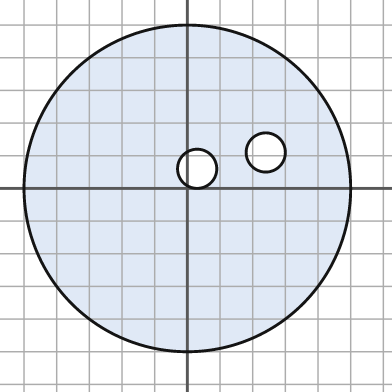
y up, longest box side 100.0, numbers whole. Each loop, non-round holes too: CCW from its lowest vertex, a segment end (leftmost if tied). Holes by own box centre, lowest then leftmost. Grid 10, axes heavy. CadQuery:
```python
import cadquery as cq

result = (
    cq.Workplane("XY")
    .moveTo(0.0, 0.0)
    .circle(50.0)
    .moveTo(3.0, 6.0)
    .circle(6.0)
    .moveTo(24.0, 11.0)
    .circle(6.0)
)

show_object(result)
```